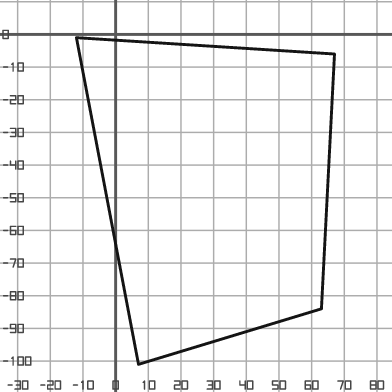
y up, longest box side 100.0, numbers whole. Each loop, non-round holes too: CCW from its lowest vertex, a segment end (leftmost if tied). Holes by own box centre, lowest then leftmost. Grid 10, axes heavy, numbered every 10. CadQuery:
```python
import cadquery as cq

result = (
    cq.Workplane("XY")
    .moveTo(7.0, -101.0)
    .lineTo(63.0, -84.0)
    .lineTo(67.0, -6.0)
    .lineTo(-12.0, -1.0)
    .close()
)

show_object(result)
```